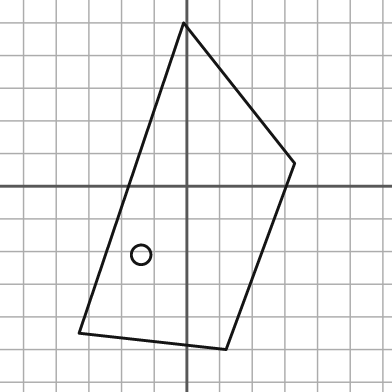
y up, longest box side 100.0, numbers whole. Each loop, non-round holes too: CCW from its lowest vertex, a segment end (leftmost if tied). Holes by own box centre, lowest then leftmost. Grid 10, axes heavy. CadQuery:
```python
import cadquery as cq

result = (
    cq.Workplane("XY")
    .moveTo(12.0, -50.0)
    .lineTo(33.0, 7.0)
    .lineTo(-1.0, 50.0)
    .lineTo(-33.0, -45.0)
    .close()
    .moveTo(-14.0, -21.0)
    .circle(3.0)
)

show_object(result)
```